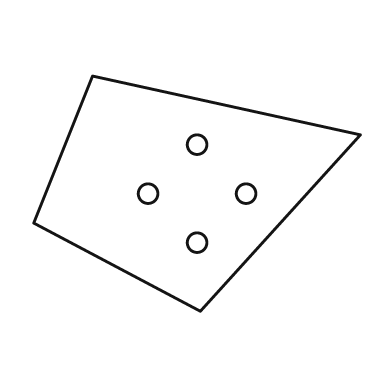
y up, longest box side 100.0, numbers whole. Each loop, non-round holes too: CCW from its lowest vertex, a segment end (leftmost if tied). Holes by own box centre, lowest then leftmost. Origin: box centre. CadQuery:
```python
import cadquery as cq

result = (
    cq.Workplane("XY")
    .moveTo(1.0, -36.0)
    .lineTo(50.0, 18.0)
    .lineTo(-32.0, 36.0)
    .lineTo(-50.0, -9.0)
    .close()
    .moveTo(0.0, -15.0)
    .circle(3.0)
    .moveTo(-15.0, 0.0)
    .circle(3.0)
    .moveTo(15.0, 0.0)
    .circle(3.0)
    .moveTo(0.0, 15.0)
    .circle(3.0)
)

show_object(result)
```